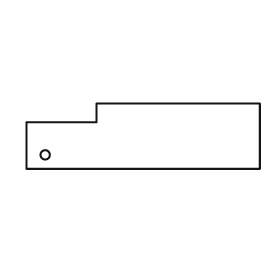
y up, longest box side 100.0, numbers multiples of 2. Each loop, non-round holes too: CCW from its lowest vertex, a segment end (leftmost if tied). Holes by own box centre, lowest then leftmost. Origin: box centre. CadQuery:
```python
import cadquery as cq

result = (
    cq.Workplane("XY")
    .moveTo(-50.0, -14.0)
    .lineTo(50.0, -14.0)
    .lineTo(50.0, 14.0)
    .lineTo(-20.0, 14.0)
    .lineTo(-20.0, 6.0)
    .lineTo(-50.0, 6.0)
    .close()
    .moveTo(-42.0, -8.0)
    .circle(2.0)
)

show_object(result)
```